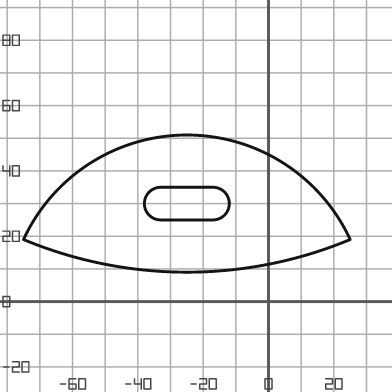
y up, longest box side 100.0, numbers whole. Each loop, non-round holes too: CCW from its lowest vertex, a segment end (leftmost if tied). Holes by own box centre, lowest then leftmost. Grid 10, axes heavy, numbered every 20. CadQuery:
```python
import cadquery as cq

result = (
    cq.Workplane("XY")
    .moveTo(-75.0, 19.0)
    .threePointArc((-25.0, 9.0), (25.0, 19.0))
    .threePointArc((-25.0, 51.0), (-75.0, 19.0))
    .close()
    .moveTo(-33.0, 25.0)
    .lineTo(-17.0, 25.0)
    .threePointArc((-12.0, 30.0), (-17.0, 35.0))
    .lineTo(-33.0, 35.0)
    .threePointArc((-38.0, 30.0), (-33.0, 25.0))
    .close()
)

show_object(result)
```